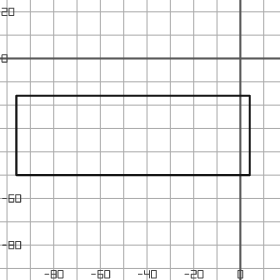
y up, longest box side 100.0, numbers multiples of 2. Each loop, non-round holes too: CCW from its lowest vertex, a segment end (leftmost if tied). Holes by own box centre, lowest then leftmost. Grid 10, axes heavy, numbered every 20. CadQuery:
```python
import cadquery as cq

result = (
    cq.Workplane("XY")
    .moveTo(-96.0, -50.0)
    .lineTo(4.0, -50.0)
    .lineTo(4.0, -16.0)
    .lineTo(-96.0, -16.0)
    .close()
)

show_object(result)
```